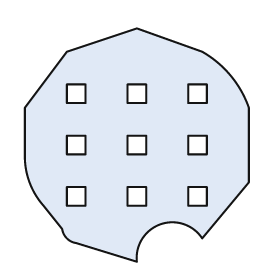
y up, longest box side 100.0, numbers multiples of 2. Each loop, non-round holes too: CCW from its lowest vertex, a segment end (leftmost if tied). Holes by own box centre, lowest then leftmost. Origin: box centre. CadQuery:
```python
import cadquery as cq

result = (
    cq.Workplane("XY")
    .moveTo(0.0, -50.0)
    .threePointArc((10.0, -34.0), (28.0, -40.0))
    .lineTo(48.0, -16.0)
    .lineTo(48.0, 16.0)
    .threePointArc((40.0, 30.0), (28.0, 40.0))
    .lineTo(0.0, 50.0)
    .lineTo(-30.0, 40.0)
    .lineTo(-48.0, 16.0)
    .lineTo(-48.0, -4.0)
    .threePointArc((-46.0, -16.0), (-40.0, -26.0))
    .lineTo(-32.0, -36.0)
    .threePointArc((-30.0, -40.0), (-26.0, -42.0))
    .close()
    .moveTo(-30.0, -26.0)
    .lineTo(-22.0, -26.0)
    .lineTo(-22.0, -18.0)
    .lineTo(-30.0, -18.0)
    .close()
    .moveTo(-4.0, -26.0)
    .lineTo(4.0, -26.0)
    .lineTo(4.0, -18.0)
    .lineTo(-4.0, -18.0)
    .close()
    .moveTo(22.0, -26.0)
    .lineTo(30.0, -26.0)
    .lineTo(30.0, -18.0)
    .lineTo(22.0, -18.0)
    .close()
    .moveTo(-30.0, -4.0)
    .lineTo(-22.0, -4.0)
    .lineTo(-22.0, 4.0)
    .lineTo(-30.0, 4.0)
    .close()
    .moveTo(-4.0, -4.0)
    .lineTo(4.0, -4.0)
    .lineTo(4.0, 4.0)
    .lineTo(-4.0, 4.0)
    .close()
    .moveTo(22.0, -4.0)
    .lineTo(30.0, -4.0)
    .lineTo(30.0, 4.0)
    .lineTo(22.0, 4.0)
    .close()
    .moveTo(-30.0, 18.0)
    .lineTo(-22.0, 18.0)
    .lineTo(-22.0, 26.0)
    .lineTo(-30.0, 26.0)
    .close()
    .moveTo(-4.0, 18.0)
    .lineTo(4.0, 18.0)
    .lineTo(4.0, 26.0)
    .lineTo(-4.0, 26.0)
    .close()
    .moveTo(22.0, 18.0)
    .lineTo(30.0, 18.0)
    .lineTo(30.0, 26.0)
    .lineTo(22.0, 26.0)
    .close()
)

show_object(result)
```